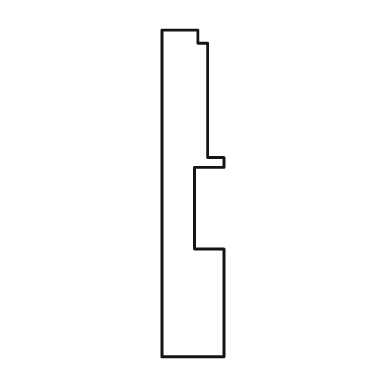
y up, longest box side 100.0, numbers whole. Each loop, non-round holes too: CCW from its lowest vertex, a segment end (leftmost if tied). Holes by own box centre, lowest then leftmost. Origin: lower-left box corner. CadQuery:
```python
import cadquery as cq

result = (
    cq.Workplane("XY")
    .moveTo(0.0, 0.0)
    .lineTo(19.0, 0.0)
    .lineTo(19.0, 33.0)
    .lineTo(10.0, 33.0)
    .lineTo(10.0, 58.0)
    .lineTo(19.0, 58.0)
    .lineTo(19.0, 61.0)
    .lineTo(14.0, 61.0)
    .lineTo(14.0, 96.0)
    .lineTo(11.0, 96.0)
    .lineTo(11.0, 100.0)
    .lineTo(0.0, 100.0)
    .close()
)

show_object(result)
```